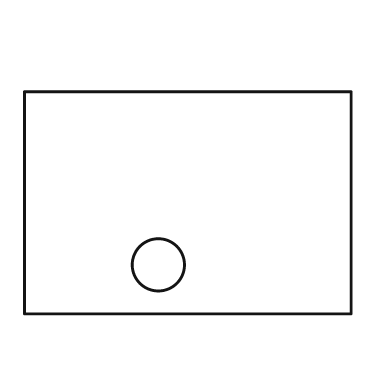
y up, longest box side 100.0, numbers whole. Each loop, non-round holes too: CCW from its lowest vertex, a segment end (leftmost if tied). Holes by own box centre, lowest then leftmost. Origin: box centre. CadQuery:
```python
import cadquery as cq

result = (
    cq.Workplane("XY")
    .moveTo(-50.0, -34.0)
    .lineTo(50.0, -34.0)
    .lineTo(50.0, 34.0)
    .lineTo(-50.0, 34.0)
    .close()
    .moveTo(-9.0, -19.0)
    .circle(8.0)
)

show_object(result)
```